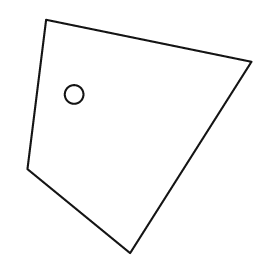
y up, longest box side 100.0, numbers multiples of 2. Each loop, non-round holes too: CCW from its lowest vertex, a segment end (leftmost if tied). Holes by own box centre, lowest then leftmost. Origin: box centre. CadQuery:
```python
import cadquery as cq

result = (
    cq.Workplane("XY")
    .moveTo(-4.0, -50.0)
    .lineTo(48.0, 32.0)
    .lineTo(-40.0, 50.0)
    .lineTo(-48.0, -14.0)
    .close()
    .moveTo(-28.0, 18.0)
    .circle(4.0)
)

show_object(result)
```